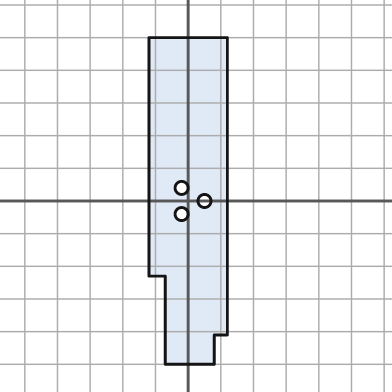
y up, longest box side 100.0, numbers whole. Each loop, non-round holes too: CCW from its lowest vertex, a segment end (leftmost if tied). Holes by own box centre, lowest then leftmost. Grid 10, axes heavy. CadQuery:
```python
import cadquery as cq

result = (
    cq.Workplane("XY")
    .moveTo(-7.0, -50.0)
    .lineTo(8.0, -50.0)
    .lineTo(8.0, -41.0)
    .lineTo(12.0, -41.0)
    .lineTo(12.0, 50.0)
    .lineTo(-12.0, 50.0)
    .lineTo(-12.0, -23.0)
    .lineTo(-7.0, -23.0)
    .close()
    .moveTo(-2.0, -4.0)
    .circle(2.0)
    .moveTo(5.0, 0.0)
    .circle(2.0)
    .moveTo(-2.0, 4.0)
    .circle(2.0)
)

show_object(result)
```